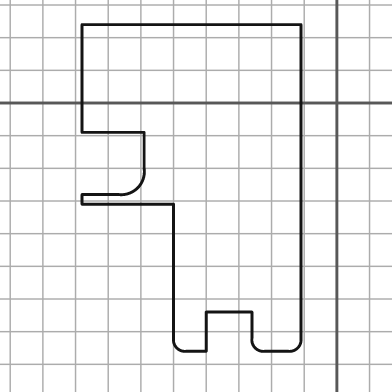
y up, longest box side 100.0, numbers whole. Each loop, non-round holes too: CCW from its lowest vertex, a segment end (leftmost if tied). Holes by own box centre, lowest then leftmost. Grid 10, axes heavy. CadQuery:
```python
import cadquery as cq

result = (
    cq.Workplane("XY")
    .moveTo(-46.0, -76.0)
    .lineTo(-40.0, -76.0)
    .lineTo(-40.0, -64.0)
    .lineTo(-26.0, -64.0)
    .lineTo(-26.0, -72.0)
    .threePointArc((-25.0, -75.0), (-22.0, -76.0))
    .lineTo(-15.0, -76.0)
    .threePointArc((-12.0, -75.0), (-11.0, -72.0))
    .lineTo(-11.0, 24.0)
    .lineTo(-78.0, 24.0)
    .lineTo(-78.0, -9.0)
    .lineTo(-59.0, -9.0)
    .lineTo(-59.0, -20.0)
    .threePointArc((-61.0, -26.0), (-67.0, -28.0))
    .lineTo(-78.0, -28.0)
    .lineTo(-78.0, -31.0)
    .lineTo(-50.0, -31.0)
    .lineTo(-50.0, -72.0)
    .threePointArc((-49.0, -75.0), (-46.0, -76.0))
    .close()
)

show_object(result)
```